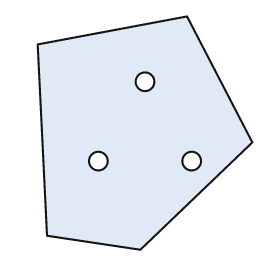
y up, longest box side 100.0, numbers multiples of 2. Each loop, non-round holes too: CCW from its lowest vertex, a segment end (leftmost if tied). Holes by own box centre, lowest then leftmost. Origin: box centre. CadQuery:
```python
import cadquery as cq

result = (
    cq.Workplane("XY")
    .moveTo(-2.0, -50.0)
    .lineTo(46.0, -4.0)
    .lineTo(18.0, 50.0)
    .lineTo(-46.0, 38.0)
    .lineTo(-42.0, -44.0)
    .close()
    .moveTo(-20.0, -12.0)
    .circle(4.0)
    .moveTo(20.0, -12.0)
    .circle(4.0)
    .moveTo(0.0, 22.0)
    .circle(4.0)
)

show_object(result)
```